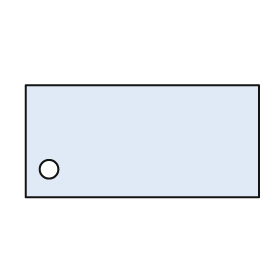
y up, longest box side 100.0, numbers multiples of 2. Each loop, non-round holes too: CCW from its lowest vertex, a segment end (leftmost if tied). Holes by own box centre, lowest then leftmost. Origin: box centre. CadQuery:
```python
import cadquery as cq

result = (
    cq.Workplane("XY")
    .moveTo(-50.0, -24.0)
    .lineTo(50.0, -24.0)
    .lineTo(50.0, 24.0)
    .lineTo(-50.0, 24.0)
    .close()
    .moveTo(-40.0, -12.0)
    .circle(4.0)
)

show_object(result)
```